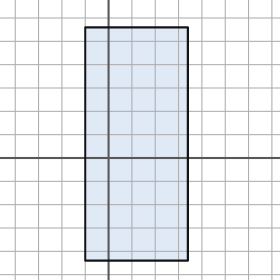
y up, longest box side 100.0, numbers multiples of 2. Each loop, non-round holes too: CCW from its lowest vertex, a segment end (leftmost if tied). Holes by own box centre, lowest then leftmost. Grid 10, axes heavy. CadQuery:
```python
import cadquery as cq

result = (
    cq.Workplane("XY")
    .moveTo(-10.0, -44.0)
    .lineTo(34.0, -44.0)
    .lineTo(34.0, 56.0)
    .lineTo(-10.0, 56.0)
    .close()
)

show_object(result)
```